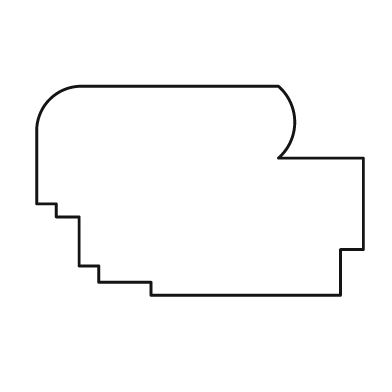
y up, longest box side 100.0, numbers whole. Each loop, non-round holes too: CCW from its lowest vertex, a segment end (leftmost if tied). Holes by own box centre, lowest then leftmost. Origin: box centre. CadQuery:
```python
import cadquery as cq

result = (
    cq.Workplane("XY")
    .moveTo(-15.0, -32.0)
    .lineTo(43.0, -32.0)
    .lineTo(43.0, -18.0)
    .lineTo(50.0, -18.0)
    .lineTo(50.0, 10.0)
    .lineTo(24.0, 10.0)
    .threePointArc((29.0, 21.0), (24.0, 32.0))
    .lineTo(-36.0, 32.0)
    .threePointArc((-46.0, 28.0), (-50.0, 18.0))
    .lineTo(-50.0, -4.0)
    .lineTo(-44.0, -4.0)
    .lineTo(-44.0, -8.0)
    .lineTo(-37.0, -8.0)
    .lineTo(-37.0, -23.0)
    .lineTo(-31.0, -23.0)
    .lineTo(-31.0, -28.0)
    .lineTo(-15.0, -28.0)
    .close()
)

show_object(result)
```